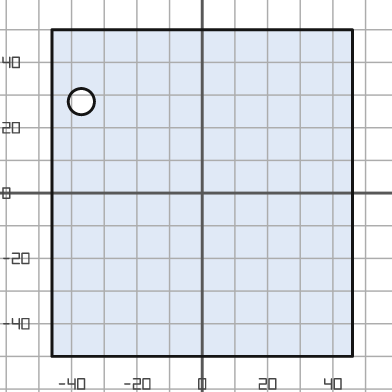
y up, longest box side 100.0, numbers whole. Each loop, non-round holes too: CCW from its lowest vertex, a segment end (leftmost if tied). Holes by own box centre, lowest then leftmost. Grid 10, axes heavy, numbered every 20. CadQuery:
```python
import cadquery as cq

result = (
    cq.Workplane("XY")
    .moveTo(-46.0, -50.0)
    .lineTo(46.0, -50.0)
    .lineTo(46.0, 50.0)
    .lineTo(-46.0, 50.0)
    .close()
    .moveTo(-37.0, 28.0)
    .circle(4.0)
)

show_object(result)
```